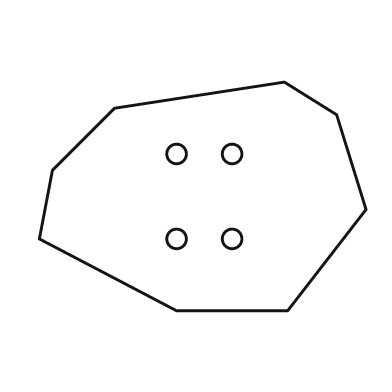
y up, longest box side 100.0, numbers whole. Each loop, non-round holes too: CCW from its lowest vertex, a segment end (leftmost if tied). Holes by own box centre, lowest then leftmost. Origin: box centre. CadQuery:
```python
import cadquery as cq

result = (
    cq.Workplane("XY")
    .moveTo(-8.0, -35.0)
    .lineTo(26.0, -35.0)
    .lineTo(50.0, -4.0)
    .lineTo(41.0, 25.0)
    .lineTo(25.0, 35.0)
    .lineTo(-27.0, 27.0)
    .lineTo(-46.0, 8.0)
    .lineTo(-50.0, -13.0)
    .close()
    .moveTo(-8.0, -13.0)
    .circle(3.0)
    .moveTo(9.0, -13.0)
    .circle(3.0)
    .moveTo(-8.0, 13.0)
    .circle(3.0)
    .moveTo(9.0, 13.0)
    .circle(3.0)
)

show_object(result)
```